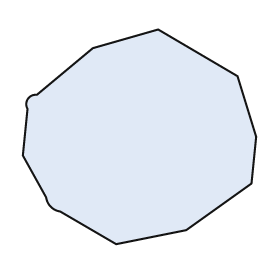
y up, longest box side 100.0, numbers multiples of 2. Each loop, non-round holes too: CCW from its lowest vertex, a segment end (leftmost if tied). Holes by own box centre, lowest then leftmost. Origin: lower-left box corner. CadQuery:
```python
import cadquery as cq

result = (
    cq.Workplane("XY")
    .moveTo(40.0, 0.0)
    .lineTo(70.0, 6.0)
    .lineTo(98.0, 26.0)
    .lineTo(100.0, 46.0)
    .lineTo(92.0, 72.0)
    .lineTo(58.0, 92.0)
    .lineTo(30.0, 84.0)
    .lineTo(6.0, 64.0)
    .threePointArc((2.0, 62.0), (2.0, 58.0))
    .lineTo(0.0, 38.0)
    .lineTo(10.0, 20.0)
    .threePointArc((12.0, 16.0), (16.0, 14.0))
    .close()
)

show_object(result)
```